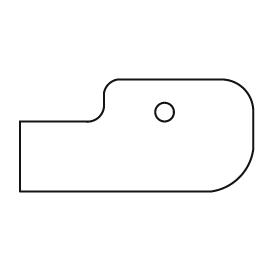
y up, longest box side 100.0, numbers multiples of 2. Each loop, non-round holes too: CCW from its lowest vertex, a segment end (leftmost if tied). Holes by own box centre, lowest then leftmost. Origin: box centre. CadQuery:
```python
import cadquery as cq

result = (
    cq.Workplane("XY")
    .moveTo(-50.0, -24.0)
    .lineTo(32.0, -24.0)
    .threePointArc((44.0, -18.0), (50.0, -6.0))
    .lineTo(50.0, 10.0)
    .threePointArc((46.0, 20.0), (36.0, 24.0))
    .lineTo(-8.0, 24.0)
    .threePointArc((-12.0, 22.0), (-14.0, 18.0))
    .lineTo(-14.0, 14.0)
    .threePointArc((-16.0, 8.0), (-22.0, 6.0))
    .lineTo(-50.0, 6.0)
    .close()
    .moveTo(12.0, 10.0)
    .circle(4.0)
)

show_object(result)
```